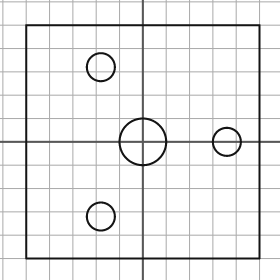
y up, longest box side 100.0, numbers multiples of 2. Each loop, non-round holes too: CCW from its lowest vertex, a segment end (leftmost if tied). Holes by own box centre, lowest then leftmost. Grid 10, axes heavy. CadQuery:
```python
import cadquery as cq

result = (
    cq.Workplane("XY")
    .moveTo(-50.0, -50.0)
    .lineTo(50.0, -50.0)
    .lineTo(50.0, 50.0)
    .lineTo(-50.0, 50.0)
    .close()
    .moveTo(-18.0, -32.0)
    .circle(6.0)
    .moveTo(0.0, 0.0)
    .circle(10.0)
    .moveTo(36.0, 0.0)
    .circle(6.0)
    .moveTo(-18.0, 32.0)
    .circle(6.0)
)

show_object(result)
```